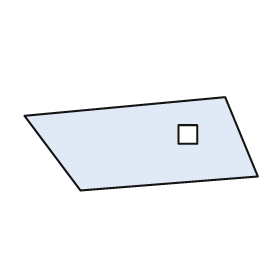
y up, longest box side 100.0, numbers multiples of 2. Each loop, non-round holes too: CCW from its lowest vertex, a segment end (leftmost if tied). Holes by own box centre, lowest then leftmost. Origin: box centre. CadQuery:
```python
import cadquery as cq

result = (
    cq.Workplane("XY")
    .moveTo(-26.0, -20.0)
    .lineTo(50.0, -14.0)
    .lineTo(36.0, 20.0)
    .lineTo(-50.0, 12.0)
    .close()
    .moveTo(16.0, 0.0)
    .lineTo(24.0, 0.0)
    .lineTo(24.0, 8.0)
    .lineTo(16.0, 8.0)
    .close()
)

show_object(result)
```